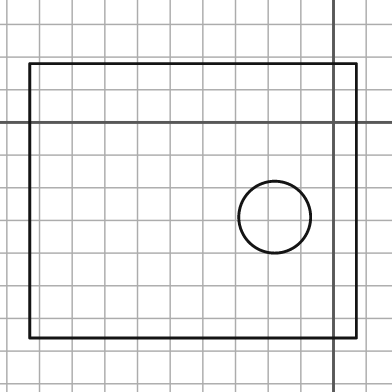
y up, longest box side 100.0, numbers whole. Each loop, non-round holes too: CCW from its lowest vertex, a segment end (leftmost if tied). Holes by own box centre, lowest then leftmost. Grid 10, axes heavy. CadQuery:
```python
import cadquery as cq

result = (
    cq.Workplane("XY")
    .moveTo(-93.0, -66.0)
    .lineTo(7.0, -66.0)
    .lineTo(7.0, 18.0)
    .lineTo(-93.0, 18.0)
    .close()
    .moveTo(-18.0, -29.0)
    .circle(11.0)
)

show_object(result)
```